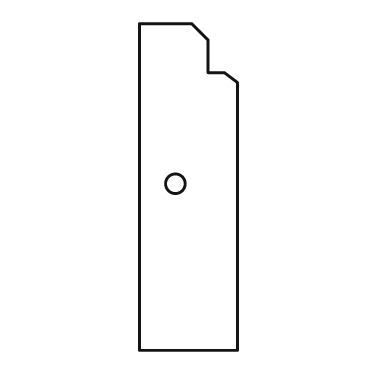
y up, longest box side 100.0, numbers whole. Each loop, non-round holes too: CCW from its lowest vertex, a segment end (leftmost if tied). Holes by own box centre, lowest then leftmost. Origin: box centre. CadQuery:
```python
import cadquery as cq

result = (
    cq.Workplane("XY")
    .moveTo(-15.0, -50.0)
    .lineTo(15.0, -50.0)
    .lineTo(15.0, 32.0)
    .lineTo(11.0, 35.0)
    .lineTo(6.0, 35.0)
    .lineTo(6.0, 45.0)
    .lineTo(1.0, 50.0)
    .lineTo(-15.0, 50.0)
    .close()
    .moveTo(-4.0, 1.0)
    .circle(3.0)
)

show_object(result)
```